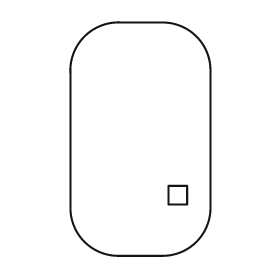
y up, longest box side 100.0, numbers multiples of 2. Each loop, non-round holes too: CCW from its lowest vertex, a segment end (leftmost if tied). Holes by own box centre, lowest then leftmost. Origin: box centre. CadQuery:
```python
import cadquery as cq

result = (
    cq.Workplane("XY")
    .moveTo(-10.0, -50.0)
    .lineTo(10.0, -50.0)
    .threePointArc((24.0, -44.0), (30.0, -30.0))
    .lineTo(30.0, 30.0)
    .threePointArc((24.0, 44.0), (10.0, 50.0))
    .lineTo(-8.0, 50.0)
    .threePointArc((-24.0, 44.0), (-30.0, 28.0))
    .lineTo(-30.0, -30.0)
    .threePointArc((-24.0, -44.0), (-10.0, -50.0))
    .close()
    .moveTo(12.0, -28.0)
    .lineTo(20.0, -28.0)
    .lineTo(20.0, -20.0)
    .lineTo(12.0, -20.0)
    .close()
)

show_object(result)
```